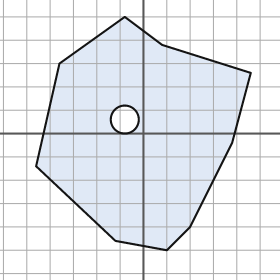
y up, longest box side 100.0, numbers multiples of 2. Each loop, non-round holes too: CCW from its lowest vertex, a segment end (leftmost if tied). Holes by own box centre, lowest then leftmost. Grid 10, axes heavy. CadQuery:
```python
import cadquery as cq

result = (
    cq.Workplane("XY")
    .moveTo(10.0, -50.0)
    .lineTo(20.0, -40.0)
    .lineTo(38.0, -4.0)
    .lineTo(46.0, 26.0)
    .lineTo(8.0, 38.0)
    .lineTo(-8.0, 50.0)
    .lineTo(-36.0, 30.0)
    .lineTo(-46.0, -14.0)
    .lineTo(-12.0, -46.0)
    .close()
    .moveTo(-8.0, 6.0)
    .circle(6.0)
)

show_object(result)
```